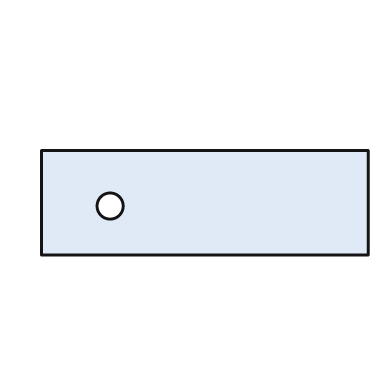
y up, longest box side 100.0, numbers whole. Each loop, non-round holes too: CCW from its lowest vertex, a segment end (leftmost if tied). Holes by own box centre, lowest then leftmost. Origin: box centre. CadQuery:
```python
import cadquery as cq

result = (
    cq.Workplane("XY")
    .moveTo(-50.0, -16.0)
    .lineTo(50.0, -16.0)
    .lineTo(50.0, 16.0)
    .lineTo(-50.0, 16.0)
    .close()
    .moveTo(-29.0, -1.0)
    .circle(4.0)
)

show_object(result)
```